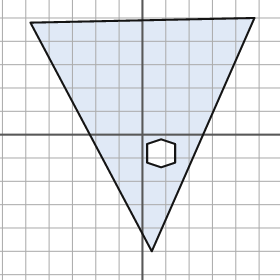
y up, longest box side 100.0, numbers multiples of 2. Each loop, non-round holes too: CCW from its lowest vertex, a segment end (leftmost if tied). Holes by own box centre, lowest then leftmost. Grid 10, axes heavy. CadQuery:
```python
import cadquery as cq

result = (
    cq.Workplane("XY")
    .moveTo(4.0, -50.0)
    .lineTo(48.0, 50.0)
    .lineTo(-48.0, 48.0)
    .close()
    .moveTo(8.0, -14.0)
    .lineTo(14.0, -12.0)
    .lineTo(14.0, -4.0)
    .lineTo(8.0, -2.0)
    .lineTo(2.0, -4.0)
    .lineTo(2.0, -12.0)
    .close()
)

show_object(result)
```